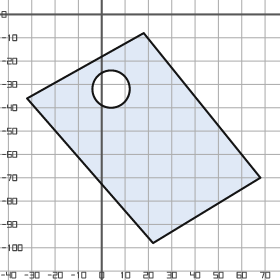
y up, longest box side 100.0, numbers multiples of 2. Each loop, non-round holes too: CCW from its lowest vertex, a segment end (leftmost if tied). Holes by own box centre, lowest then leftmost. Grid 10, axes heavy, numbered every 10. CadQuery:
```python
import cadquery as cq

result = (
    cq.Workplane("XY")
    .moveTo(22.0, -98.0)
    .lineTo(68.0, -70.0)
    .lineTo(18.0, -8.0)
    .lineTo(-32.0, -36.0)
    .close()
    .moveTo(4.0, -32.0)
    .circle(8.0)
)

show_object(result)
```